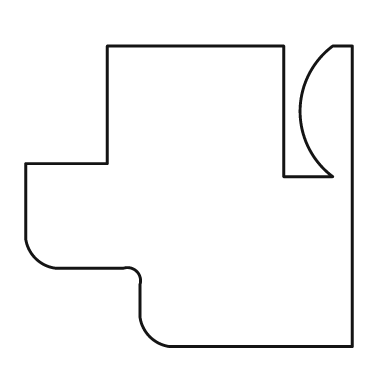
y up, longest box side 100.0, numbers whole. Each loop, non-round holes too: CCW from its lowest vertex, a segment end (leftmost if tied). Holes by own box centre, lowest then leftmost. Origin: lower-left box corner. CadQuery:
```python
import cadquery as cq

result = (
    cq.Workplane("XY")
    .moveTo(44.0, 0.0)
    .lineTo(100.0, 0.0)
    .lineTo(100.0, 92.0)
    .lineTo(94.0, 92.0)
    .threePointArc((84.0, 72.0), (94.0, 52.0))
    .lineTo(79.0, 52.0)
    .lineTo(79.0, 92.0)
    .lineTo(25.0, 92.0)
    .lineTo(25.0, 56.0)
    .lineTo(0.0, 56.0)
    .lineTo(0.0, 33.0)
    .threePointArc((3.0, 27.0), (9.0, 24.0))
    .lineTo(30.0, 24.0)
    .threePointArc((34.0, 23.0), (35.0, 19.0))
    .lineTo(35.0, 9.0)
    .threePointArc((38.0, 3.0), (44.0, 0.0))
    .close()
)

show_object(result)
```